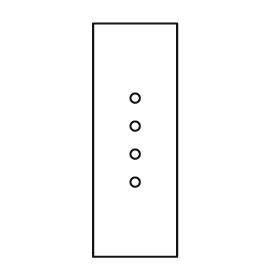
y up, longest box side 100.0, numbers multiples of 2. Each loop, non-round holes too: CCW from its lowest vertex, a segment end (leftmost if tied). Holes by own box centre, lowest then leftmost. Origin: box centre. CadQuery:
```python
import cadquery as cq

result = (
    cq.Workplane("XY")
    .moveTo(-18.0, -50.0)
    .lineTo(18.0, -50.0)
    .lineTo(18.0, 50.0)
    .lineTo(-18.0, 50.0)
    .close()
    .moveTo(0.0, -18.0)
    .circle(2.0)
    .moveTo(0.0, -6.0)
    .circle(2.0)
    .moveTo(0.0, 6.0)
    .circle(2.0)
    .moveTo(0.0, 18.0)
    .circle(2.0)
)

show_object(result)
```